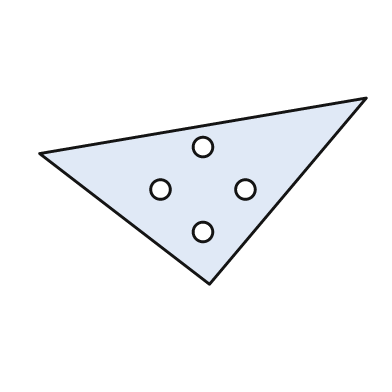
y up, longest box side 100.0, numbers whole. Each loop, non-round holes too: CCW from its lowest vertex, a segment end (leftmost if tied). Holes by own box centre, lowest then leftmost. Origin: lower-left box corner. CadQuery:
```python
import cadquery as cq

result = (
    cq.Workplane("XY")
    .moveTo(52.0, 0.0)
    .lineTo(100.0, 57.0)
    .lineTo(0.0, 40.0)
    .close()
    .moveTo(50.0, 16.0)
    .circle(3.0)
    .moveTo(37.0, 29.0)
    .circle(3.0)
    .moveTo(63.0, 29.0)
    .circle(3.0)
    .moveTo(50.0, 42.0)
    .circle(3.0)
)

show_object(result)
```